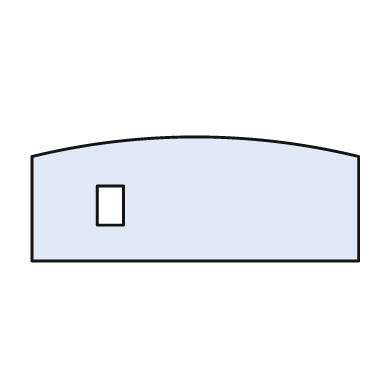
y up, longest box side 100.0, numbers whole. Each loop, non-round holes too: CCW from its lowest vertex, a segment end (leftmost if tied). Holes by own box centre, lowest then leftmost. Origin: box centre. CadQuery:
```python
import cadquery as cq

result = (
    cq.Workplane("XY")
    .moveTo(-50.0, -19.0)
    .lineTo(50.0, -19.0)
    .lineTo(50.0, 13.0)
    .threePointArc((0.0, 19.0), (-50.0, 13.0))
    .close()
    .moveTo(-30.0, -8.0)
    .lineTo(-22.0, -8.0)
    .lineTo(-22.0, 4.0)
    .lineTo(-30.0, 4.0)
    .close()
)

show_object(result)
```